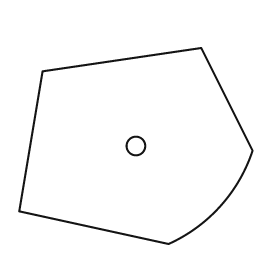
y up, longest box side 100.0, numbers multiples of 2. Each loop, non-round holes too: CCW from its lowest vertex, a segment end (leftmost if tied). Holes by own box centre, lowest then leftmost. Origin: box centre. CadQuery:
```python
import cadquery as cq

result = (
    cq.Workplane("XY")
    .moveTo(14.0, -42.0)
    .threePointArc((36.0, -26.0), (50.0, -2.0))
    .lineTo(28.0, 42.0)
    .lineTo(-40.0, 32.0)
    .lineTo(-50.0, -28.0)
    .close()
    .moveTo(0.0, 0.0)
    .circle(4.0)
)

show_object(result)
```